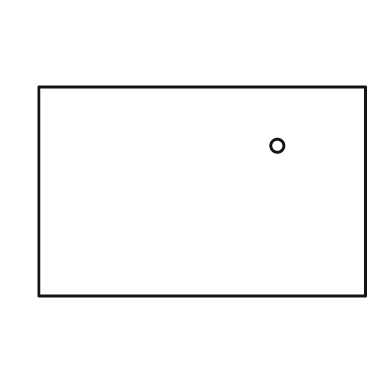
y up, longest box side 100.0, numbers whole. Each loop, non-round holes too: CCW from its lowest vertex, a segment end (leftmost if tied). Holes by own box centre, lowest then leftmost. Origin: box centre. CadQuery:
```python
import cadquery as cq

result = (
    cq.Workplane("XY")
    .moveTo(-50.0, -32.0)
    .lineTo(50.0, -32.0)
    .lineTo(50.0, 32.0)
    .lineTo(-50.0, 32.0)
    .close()
    .moveTo(23.0, 14.0)
    .circle(2.0)
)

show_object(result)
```